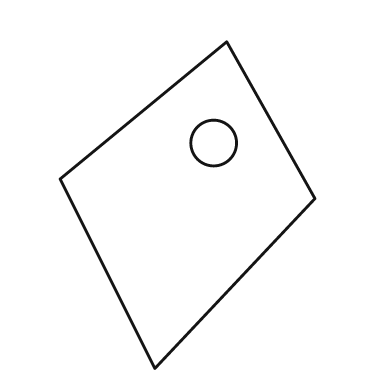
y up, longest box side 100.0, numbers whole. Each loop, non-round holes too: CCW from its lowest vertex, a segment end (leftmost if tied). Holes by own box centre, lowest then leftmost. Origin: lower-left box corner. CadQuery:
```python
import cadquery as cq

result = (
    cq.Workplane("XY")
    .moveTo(29.0, 0.0)
    .lineTo(78.0, 52.0)
    .lineTo(51.0, 100.0)
    .lineTo(0.0, 58.0)
    .close()
    .moveTo(47.0, 69.0)
    .circle(7.0)
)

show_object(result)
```